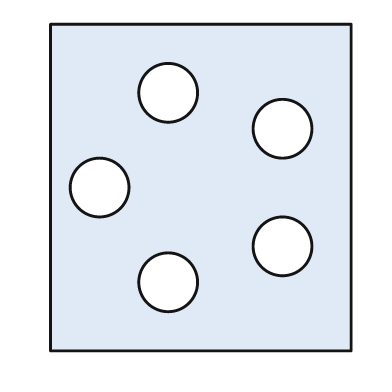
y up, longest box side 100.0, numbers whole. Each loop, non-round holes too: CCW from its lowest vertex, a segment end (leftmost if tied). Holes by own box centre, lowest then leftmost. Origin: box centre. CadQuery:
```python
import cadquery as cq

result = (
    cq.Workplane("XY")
    .moveTo(-46.0, -50.0)
    .lineTo(46.0, -50.0)
    .lineTo(46.0, 50.0)
    .lineTo(-46.0, 50.0)
    .close()
    .moveTo(-10.0, -29.0)
    .circle(9.0)
    .moveTo(25.0, -18.0)
    .circle(9.0)
    .moveTo(-31.0, 0.0)
    .circle(9.0)
    .moveTo(25.0, 18.0)
    .circle(9.0)
    .moveTo(-10.0, 29.0)
    .circle(9.0)
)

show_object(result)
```